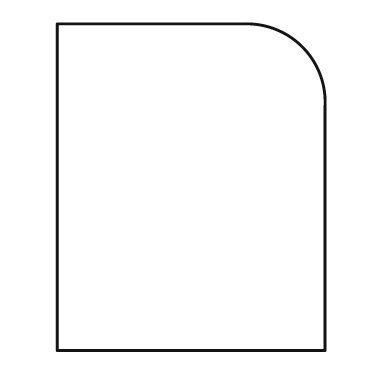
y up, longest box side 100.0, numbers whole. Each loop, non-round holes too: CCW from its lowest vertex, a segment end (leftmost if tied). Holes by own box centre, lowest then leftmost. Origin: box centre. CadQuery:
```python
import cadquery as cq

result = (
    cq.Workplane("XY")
    .moveTo(-41.0, -50.0)
    .lineTo(41.0, -50.0)
    .lineTo(41.0, 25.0)
    .threePointArc((34.0, 43.0), (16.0, 50.0))
    .lineTo(-41.0, 50.0)
    .close()
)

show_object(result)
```